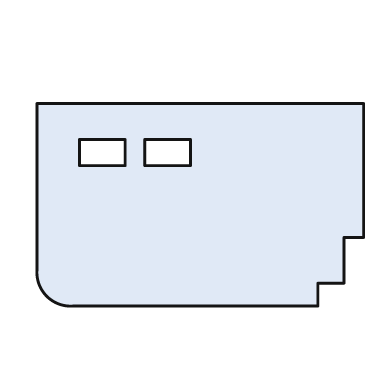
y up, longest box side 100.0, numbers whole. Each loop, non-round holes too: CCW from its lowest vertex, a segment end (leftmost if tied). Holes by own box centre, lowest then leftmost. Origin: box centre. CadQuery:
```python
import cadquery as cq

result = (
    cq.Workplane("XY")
    .moveTo(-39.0, -31.0)
    .lineTo(36.0, -31.0)
    .lineTo(36.0, -24.0)
    .lineTo(44.0, -24.0)
    .lineTo(44.0, -10.0)
    .lineTo(50.0, -10.0)
    .lineTo(50.0, 31.0)
    .lineTo(-50.0, 31.0)
    .lineTo(-50.0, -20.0)
    .threePointArc((-47.0, -28.0), (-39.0, -31.0))
    .close()
    .moveTo(-37.0, 12.0)
    .lineTo(-23.0, 12.0)
    .lineTo(-23.0, 20.0)
    .lineTo(-37.0, 20.0)
    .close()
    .moveTo(-17.0, 12.0)
    .lineTo(-3.0, 12.0)
    .lineTo(-3.0, 20.0)
    .lineTo(-17.0, 20.0)
    .close()
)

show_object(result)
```